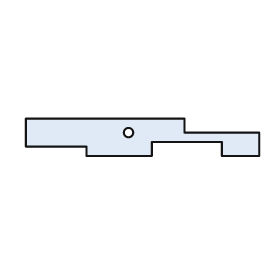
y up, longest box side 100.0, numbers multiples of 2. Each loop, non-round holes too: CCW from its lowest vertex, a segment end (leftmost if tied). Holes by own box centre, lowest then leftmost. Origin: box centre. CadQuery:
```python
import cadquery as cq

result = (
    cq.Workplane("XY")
    .moveTo(-24.0, -8.0)
    .lineTo(4.0, -8.0)
    .lineTo(4.0, -2.0)
    .lineTo(34.0, -2.0)
    .lineTo(34.0, -8.0)
    .lineTo(50.0, -8.0)
    .lineTo(50.0, 2.0)
    .lineTo(18.0, 2.0)
    .lineTo(18.0, 8.0)
    .lineTo(-50.0, 8.0)
    .lineTo(-50.0, -4.0)
    .lineTo(-24.0, -4.0)
    .close()
    .moveTo(-6.0, 2.0)
    .circle(2.0)
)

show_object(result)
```